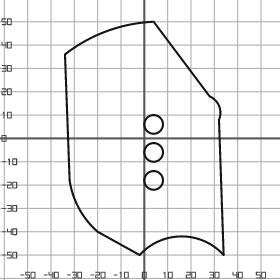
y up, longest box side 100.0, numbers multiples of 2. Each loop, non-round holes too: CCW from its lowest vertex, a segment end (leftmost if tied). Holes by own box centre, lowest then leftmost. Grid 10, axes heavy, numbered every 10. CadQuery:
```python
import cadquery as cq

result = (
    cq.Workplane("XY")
    .moveTo(-2.0, -50.0)
    .threePointArc((16.0, -42.0), (34.0, -50.0))
    .lineTo(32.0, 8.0)
    .threePointArc((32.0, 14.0), (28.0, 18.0))
    .lineTo(4.0, 50.0)
    .threePointArc((-16.0, 46.0), (-34.0, 36.0))
    .lineTo(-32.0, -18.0)
    .threePointArc((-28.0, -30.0), (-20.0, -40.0))
    .close()
    .moveTo(4.0, -18.0)
    .circle(4.0)
    .moveTo(4.0, -6.0)
    .circle(4.0)
    .moveTo(4.0, 6.0)
    .circle(4.0)
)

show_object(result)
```